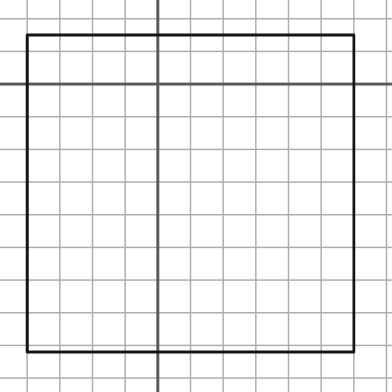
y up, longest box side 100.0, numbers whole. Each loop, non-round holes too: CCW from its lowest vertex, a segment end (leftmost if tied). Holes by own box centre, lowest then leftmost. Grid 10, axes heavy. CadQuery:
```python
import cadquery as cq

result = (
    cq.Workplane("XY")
    .moveTo(-40.0, -82.0)
    .lineTo(60.0, -82.0)
    .lineTo(60.0, 15.0)
    .lineTo(-40.0, 15.0)
    .close()
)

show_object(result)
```